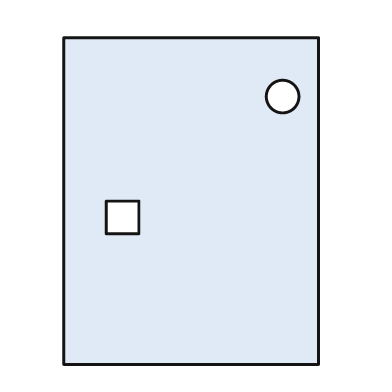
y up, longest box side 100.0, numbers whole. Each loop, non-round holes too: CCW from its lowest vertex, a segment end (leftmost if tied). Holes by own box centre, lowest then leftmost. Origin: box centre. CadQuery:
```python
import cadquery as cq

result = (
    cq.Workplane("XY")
    .moveTo(-39.0, -50.0)
    .lineTo(39.0, -50.0)
    .lineTo(39.0, 50.0)
    .lineTo(-39.0, 50.0)
    .close()
    .moveTo(-26.0, -10.0)
    .lineTo(-16.0, -10.0)
    .lineTo(-16.0, 0.0)
    .lineTo(-26.0, 0.0)
    .close()
    .moveTo(28.0, 32.0)
    .circle(5.0)
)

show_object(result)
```